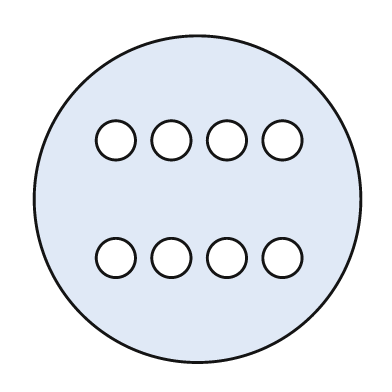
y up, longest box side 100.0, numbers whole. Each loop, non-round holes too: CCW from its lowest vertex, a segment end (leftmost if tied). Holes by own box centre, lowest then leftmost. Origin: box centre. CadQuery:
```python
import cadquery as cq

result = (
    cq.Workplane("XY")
    .moveTo(0.0, 0.0)
    .circle(50.0)
    .moveTo(-25.0, -18.0)
    .circle(6.0)
    .moveTo(-8.0, -18.0)
    .circle(6.0)
    .moveTo(9.0, -18.0)
    .circle(6.0)
    .moveTo(26.0, -18.0)
    .circle(6.0)
    .moveTo(-25.0, 18.0)
    .circle(6.0)
    .moveTo(-8.0, 18.0)
    .circle(6.0)
    .moveTo(9.0, 18.0)
    .circle(6.0)
    .moveTo(26.0, 18.0)
    .circle(6.0)
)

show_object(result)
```